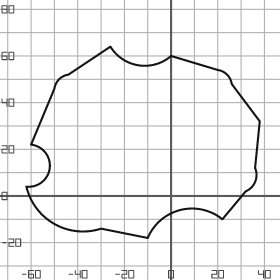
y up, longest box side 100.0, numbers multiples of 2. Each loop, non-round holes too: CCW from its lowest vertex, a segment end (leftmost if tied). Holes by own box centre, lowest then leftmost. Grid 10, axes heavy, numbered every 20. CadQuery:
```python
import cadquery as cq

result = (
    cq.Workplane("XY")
    .moveTo(-10.0, -18.0)
    .threePointArc((4.0, -6.0), (22.0, -10.0))
    .lineTo(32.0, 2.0)
    .threePointArc((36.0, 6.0), (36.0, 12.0))
    .lineTo(38.0, 32.0)
    .lineTo(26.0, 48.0)
    .threePointArc((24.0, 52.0), (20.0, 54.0))
    .lineTo(0.0, 60.0)
    .threePointArc((-14.0, 56.0), (-26.0, 64.0))
    .lineTo(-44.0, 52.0)
    .threePointArc((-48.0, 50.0), (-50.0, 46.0))
    .lineTo(-60.0, 22.0)
    .threePointArc((-52.0, 12.0), (-62.0, 4.0))
    .threePointArc((-50.0, -12.0), (-30.0, -14.0))
    .close()
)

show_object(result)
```